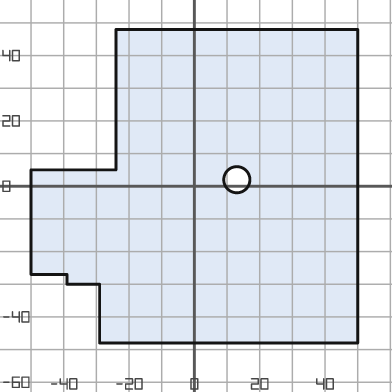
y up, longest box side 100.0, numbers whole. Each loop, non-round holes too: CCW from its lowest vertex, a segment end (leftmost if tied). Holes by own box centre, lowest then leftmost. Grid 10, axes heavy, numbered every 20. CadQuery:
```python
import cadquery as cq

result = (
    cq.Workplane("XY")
    .moveTo(-29.0, -48.0)
    .lineTo(50.0, -48.0)
    .lineTo(50.0, 48.0)
    .lineTo(-24.0, 48.0)
    .lineTo(-24.0, 5.0)
    .lineTo(-50.0, 5.0)
    .lineTo(-50.0, -27.0)
    .lineTo(-39.0, -27.0)
    .lineTo(-39.0, -30.0)
    .lineTo(-29.0, -30.0)
    .close()
    .moveTo(13.0, 2.0)
    .circle(4.0)
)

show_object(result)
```